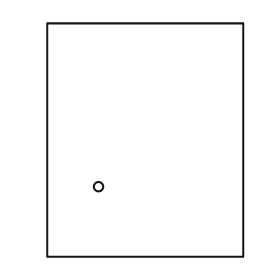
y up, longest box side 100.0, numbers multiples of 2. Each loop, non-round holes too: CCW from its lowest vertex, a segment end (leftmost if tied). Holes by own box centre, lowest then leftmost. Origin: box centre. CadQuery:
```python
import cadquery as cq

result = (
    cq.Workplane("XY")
    .moveTo(-42.0, -50.0)
    .lineTo(42.0, -50.0)
    .lineTo(42.0, 50.0)
    .lineTo(-42.0, 50.0)
    .close()
    .moveTo(-20.0, -20.0)
    .circle(2.0)
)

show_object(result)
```